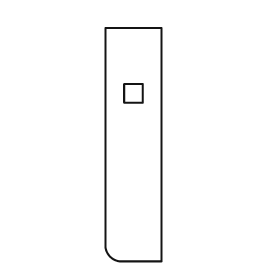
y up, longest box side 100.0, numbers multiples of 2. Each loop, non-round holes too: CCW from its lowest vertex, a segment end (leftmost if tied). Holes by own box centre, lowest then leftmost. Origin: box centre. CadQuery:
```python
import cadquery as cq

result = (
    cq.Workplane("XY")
    .moveTo(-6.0, -50.0)
    .lineTo(12.0, -50.0)
    .lineTo(12.0, 50.0)
    .lineTo(-12.0, 50.0)
    .lineTo(-12.0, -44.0)
    .threePointArc((-10.0, -48.0), (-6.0, -50.0))
    .close()
    .moveTo(-4.0, 18.0)
    .lineTo(4.0, 18.0)
    .lineTo(4.0, 26.0)
    .lineTo(-4.0, 26.0)
    .close()
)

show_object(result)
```